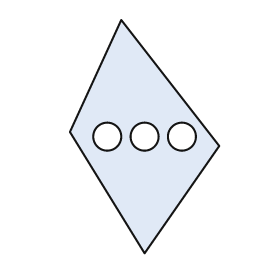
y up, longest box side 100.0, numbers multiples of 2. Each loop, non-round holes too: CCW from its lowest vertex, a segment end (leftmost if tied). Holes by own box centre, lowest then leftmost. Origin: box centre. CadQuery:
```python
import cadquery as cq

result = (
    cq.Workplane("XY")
    .moveTo(0.0, -50.0)
    .lineTo(32.0, -4.0)
    .lineTo(-10.0, 50.0)
    .lineTo(-32.0, 2.0)
    .close()
    .moveTo(-16.0, 0.0)
    .circle(6.0)
    .moveTo(0.0, 0.0)
    .circle(6.0)
    .moveTo(16.0, 0.0)
    .circle(6.0)
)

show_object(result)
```